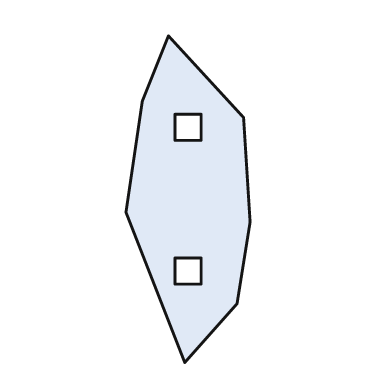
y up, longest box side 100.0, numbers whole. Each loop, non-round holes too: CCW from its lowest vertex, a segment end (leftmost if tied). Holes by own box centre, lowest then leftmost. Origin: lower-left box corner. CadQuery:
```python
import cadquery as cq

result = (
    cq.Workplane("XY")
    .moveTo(18.0, 0.0)
    .lineTo(34.0, 18.0)
    .lineTo(38.0, 43.0)
    .lineTo(36.0, 75.0)
    .lineTo(13.0, 100.0)
    .lineTo(5.0, 80.0)
    .lineTo(0.0, 46.0)
    .close()
    .moveTo(15.0, 24.0)
    .lineTo(23.0, 24.0)
    .lineTo(23.0, 32.0)
    .lineTo(15.0, 32.0)
    .close()
    .moveTo(15.0, 68.0)
    .lineTo(23.0, 68.0)
    .lineTo(23.0, 76.0)
    .lineTo(15.0, 76.0)
    .close()
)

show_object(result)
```